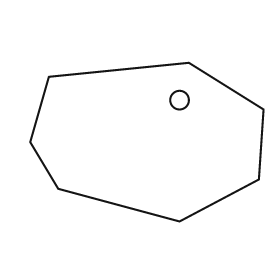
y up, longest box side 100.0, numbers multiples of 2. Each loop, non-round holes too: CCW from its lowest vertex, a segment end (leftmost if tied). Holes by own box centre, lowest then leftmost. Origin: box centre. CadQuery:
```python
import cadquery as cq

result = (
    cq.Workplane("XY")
    .moveTo(14.0, -34.0)
    .lineTo(48.0, -16.0)
    .lineTo(50.0, 14.0)
    .lineTo(18.0, 34.0)
    .lineTo(-42.0, 28.0)
    .lineTo(-50.0, 0.0)
    .lineTo(-38.0, -20.0)
    .close()
    .moveTo(14.0, 18.0)
    .circle(4.0)
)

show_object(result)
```